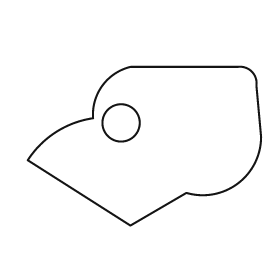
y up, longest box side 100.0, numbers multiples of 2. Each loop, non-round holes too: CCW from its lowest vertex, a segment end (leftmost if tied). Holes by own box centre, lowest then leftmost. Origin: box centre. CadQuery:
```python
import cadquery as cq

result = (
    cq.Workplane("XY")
    .moveTo(-6.0, -34.0)
    .lineTo(18.0, -20.0)
    .threePointArc((40.0, -16.0), (50.0, 4.0))
    .lineTo(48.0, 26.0)
    .threePointArc((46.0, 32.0), (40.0, 34.0))
    .lineTo(-6.0, 34.0)
    .threePointArc((-18.0, 26.0), (-22.0, 12.0))
    .threePointArc((-38.0, 6.0), (-50.0, -6.0))
    .close()
    .moveTo(-10.0, 10.0)
    .circle(8.0)
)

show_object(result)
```